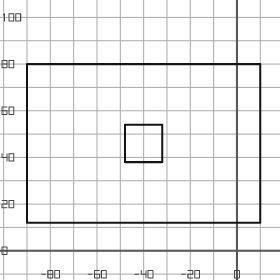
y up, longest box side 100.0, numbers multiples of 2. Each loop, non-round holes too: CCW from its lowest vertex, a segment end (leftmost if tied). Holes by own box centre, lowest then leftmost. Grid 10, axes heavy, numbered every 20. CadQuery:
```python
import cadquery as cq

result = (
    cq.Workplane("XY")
    .moveTo(-90.0, 12.0)
    .lineTo(10.0, 12.0)
    .lineTo(10.0, 80.0)
    .lineTo(-90.0, 80.0)
    .close()
    .moveTo(-48.0, 38.0)
    .lineTo(-32.0, 38.0)
    .lineTo(-32.0, 54.0)
    .lineTo(-48.0, 54.0)
    .close()
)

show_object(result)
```